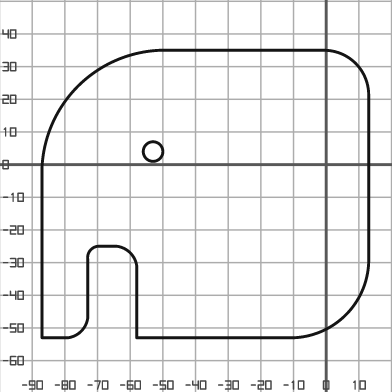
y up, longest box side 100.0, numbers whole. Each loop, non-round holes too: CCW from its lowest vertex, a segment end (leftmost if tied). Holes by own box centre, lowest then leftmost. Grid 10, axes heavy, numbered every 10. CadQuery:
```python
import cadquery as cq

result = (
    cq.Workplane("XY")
    .moveTo(-87.0, -53.0)
    .lineTo(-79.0, -53.0)
    .threePointArc((-75.0, -51.0), (-73.0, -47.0))
    .lineTo(-73.0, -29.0)
    .threePointArc((-72.0, -26.0), (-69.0, -25.0))
    .lineTo(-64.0, -25.0)
    .threePointArc((-60.0, -27.0), (-58.0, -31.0))
    .lineTo(-58.0, -53.0)
    .lineTo(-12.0, -53.0)
    .threePointArc((6.0, -46.0), (13.0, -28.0))
    .lineTo(13.0, 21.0)
    .threePointArc((9.0, 31.0), (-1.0, 35.0))
    .lineTo(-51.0, 35.0)
    .threePointArc((-76.0, 24.0), (-87.0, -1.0))
    .close()
    .moveTo(-53.0, 4.0)
    .circle(3.0)
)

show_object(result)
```